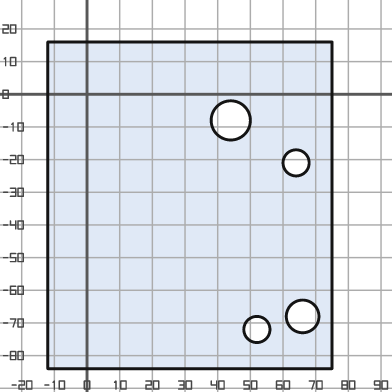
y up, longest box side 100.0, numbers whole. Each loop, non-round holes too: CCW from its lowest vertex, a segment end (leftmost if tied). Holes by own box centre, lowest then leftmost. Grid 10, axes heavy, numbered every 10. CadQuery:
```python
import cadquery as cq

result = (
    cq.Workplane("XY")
    .moveTo(-12.0, -84.0)
    .lineTo(75.0, -84.0)
    .lineTo(75.0, 16.0)
    .lineTo(-12.0, 16.0)
    .close()
    .moveTo(52.0, -72.0)
    .circle(4.0)
    .moveTo(66.0, -68.0)
    .circle(5.0)
    .moveTo(64.0, -21.0)
    .circle(4.0)
    .moveTo(44.0, -8.0)
    .circle(6.0)
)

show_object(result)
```